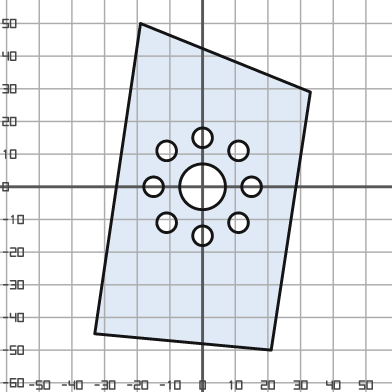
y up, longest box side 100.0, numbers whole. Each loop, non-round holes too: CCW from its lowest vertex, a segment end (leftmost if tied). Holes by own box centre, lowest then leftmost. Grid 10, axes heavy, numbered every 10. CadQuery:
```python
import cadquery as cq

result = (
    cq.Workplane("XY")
    .moveTo(21.0, -50.0)
    .lineTo(33.0, 29.0)
    .lineTo(-19.0, 50.0)
    .lineTo(-33.0, -45.0)
    .close()
    .moveTo(0.0, -15.0)
    .circle(3.0)
    .moveTo(-11.0, -11.0)
    .circle(3.0)
    .moveTo(11.0, -11.0)
    .circle(3.0)
    .moveTo(-15.0, 0.0)
    .circle(3.0)
    .moveTo(0.0, 0.0)
    .circle(7.0)
    .moveTo(15.0, 0.0)
    .circle(3.0)
    .moveTo(-11.0, 11.0)
    .circle(3.0)
    .moveTo(11.0, 11.0)
    .circle(3.0)
    .moveTo(0.0, 15.0)
    .circle(3.0)
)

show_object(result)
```